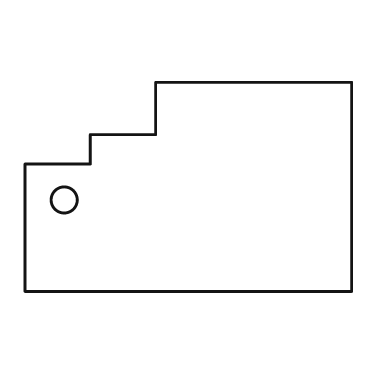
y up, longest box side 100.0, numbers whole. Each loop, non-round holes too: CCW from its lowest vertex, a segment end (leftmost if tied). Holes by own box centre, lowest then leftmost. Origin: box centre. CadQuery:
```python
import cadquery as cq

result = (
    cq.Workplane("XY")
    .moveTo(-50.0, -32.0)
    .lineTo(50.0, -32.0)
    .lineTo(50.0, 32.0)
    .lineTo(-10.0, 32.0)
    .lineTo(-10.0, 16.0)
    .lineTo(-30.0, 16.0)
    .lineTo(-30.0, 7.0)
    .lineTo(-50.0, 7.0)
    .close()
    .moveTo(-38.0, -4.0)
    .circle(4.0)
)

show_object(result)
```